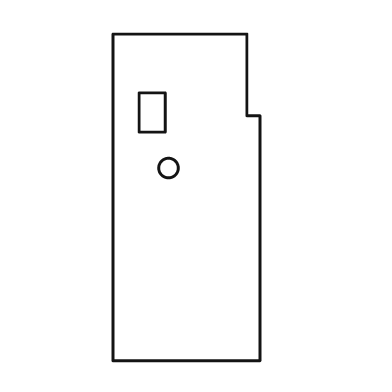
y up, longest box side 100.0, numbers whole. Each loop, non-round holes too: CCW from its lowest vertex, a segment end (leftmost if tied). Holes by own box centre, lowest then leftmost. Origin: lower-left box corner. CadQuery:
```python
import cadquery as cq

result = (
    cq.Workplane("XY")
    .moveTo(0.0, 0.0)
    .lineTo(45.0, 0.0)
    .lineTo(45.0, 75.0)
    .lineTo(41.0, 75.0)
    .lineTo(41.0, 100.0)
    .lineTo(0.0, 100.0)
    .close()
    .moveTo(17.0, 59.0)
    .circle(3.0)
    .moveTo(8.0, 70.0)
    .lineTo(16.0, 70.0)
    .lineTo(16.0, 82.0)
    .lineTo(8.0, 82.0)
    .close()
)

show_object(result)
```